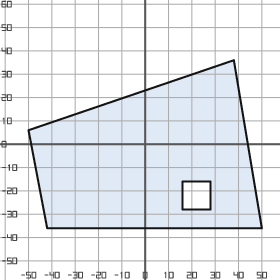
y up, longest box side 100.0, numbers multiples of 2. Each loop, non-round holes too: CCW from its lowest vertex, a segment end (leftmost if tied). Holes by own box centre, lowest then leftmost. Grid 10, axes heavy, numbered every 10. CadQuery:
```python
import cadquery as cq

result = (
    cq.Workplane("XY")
    .moveTo(-42.0, -36.0)
    .lineTo(50.0, -36.0)
    .lineTo(38.0, 36.0)
    .lineTo(-50.0, 6.0)
    .close()
    .moveTo(16.0, -28.0)
    .lineTo(28.0, -28.0)
    .lineTo(28.0, -16.0)
    .lineTo(16.0, -16.0)
    .close()
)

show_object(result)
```